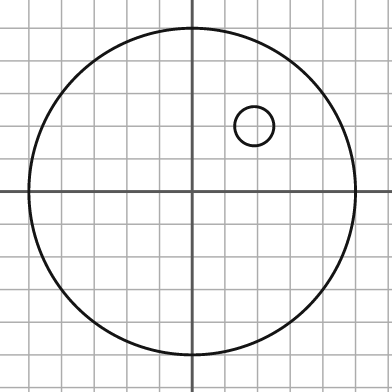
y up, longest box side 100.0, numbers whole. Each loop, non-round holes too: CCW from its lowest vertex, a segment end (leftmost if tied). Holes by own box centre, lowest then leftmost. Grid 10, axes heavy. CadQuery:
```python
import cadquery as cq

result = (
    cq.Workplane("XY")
    .moveTo(0.0, 0.0)
    .circle(50.0)
    .moveTo(19.0, 20.0)
    .circle(6.0)
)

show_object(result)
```